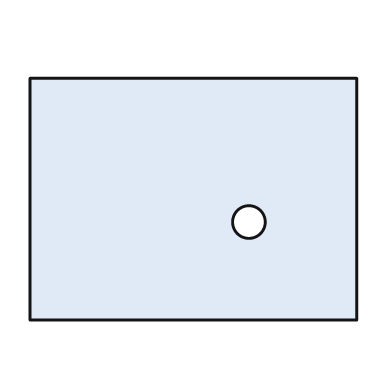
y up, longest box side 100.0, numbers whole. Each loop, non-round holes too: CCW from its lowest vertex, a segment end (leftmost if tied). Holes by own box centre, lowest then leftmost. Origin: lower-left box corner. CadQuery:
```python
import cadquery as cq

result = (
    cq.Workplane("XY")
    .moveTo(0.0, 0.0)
    .lineTo(100.0, 0.0)
    .lineTo(100.0, 74.0)
    .lineTo(0.0, 74.0)
    .close()
    .moveTo(67.0, 30.0)
    .circle(5.0)
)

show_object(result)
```